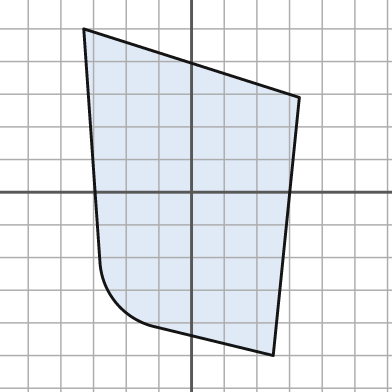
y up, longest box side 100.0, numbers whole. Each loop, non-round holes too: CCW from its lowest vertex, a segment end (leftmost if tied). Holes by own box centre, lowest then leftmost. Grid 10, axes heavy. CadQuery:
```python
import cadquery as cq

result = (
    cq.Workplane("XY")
    .moveTo(25.0, -50.0)
    .lineTo(33.0, 29.0)
    .lineTo(-33.0, 50.0)
    .lineTo(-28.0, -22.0)
    .threePointArc((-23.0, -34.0), (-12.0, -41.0))
    .close()
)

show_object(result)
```